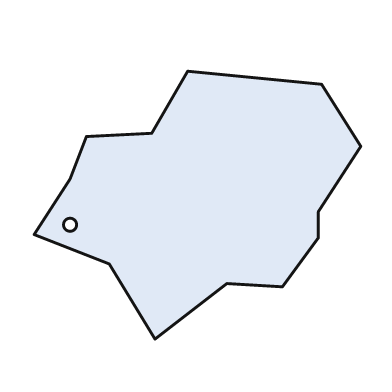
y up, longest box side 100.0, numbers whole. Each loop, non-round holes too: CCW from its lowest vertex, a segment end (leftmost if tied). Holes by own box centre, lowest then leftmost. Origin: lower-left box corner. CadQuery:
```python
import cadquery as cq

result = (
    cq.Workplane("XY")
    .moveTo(37.0, 0.0)
    .lineTo(59.0, 17.0)
    .lineTo(76.0, 16.0)
    .lineTo(87.0, 31.0)
    .lineTo(87.0, 39.0)
    .lineTo(100.0, 59.0)
    .lineTo(88.0, 78.0)
    .lineTo(47.0, 82.0)
    .lineTo(36.0, 63.0)
    .lineTo(16.0, 62.0)
    .lineTo(11.0, 49.0)
    .lineTo(0.0, 32.0)
    .lineTo(23.0, 23.0)
    .close()
    .moveTo(11.0, 35.0)
    .circle(2.0)
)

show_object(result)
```